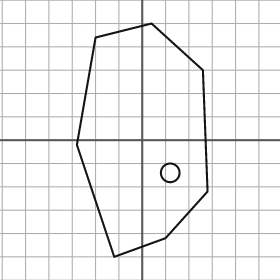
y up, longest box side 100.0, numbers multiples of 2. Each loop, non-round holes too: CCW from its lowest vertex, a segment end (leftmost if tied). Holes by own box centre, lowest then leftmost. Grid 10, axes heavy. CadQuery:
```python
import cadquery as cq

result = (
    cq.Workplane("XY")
    .moveTo(-12.0, -50.0)
    .lineTo(10.0, -42.0)
    .lineTo(28.0, -22.0)
    .lineTo(26.0, 30.0)
    .lineTo(4.0, 50.0)
    .lineTo(-20.0, 44.0)
    .lineTo(-28.0, -2.0)
    .close()
    .moveTo(12.0, -14.0)
    .circle(4.0)
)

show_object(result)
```